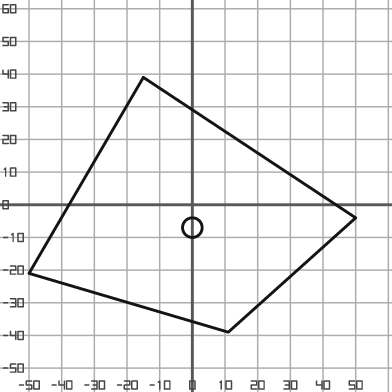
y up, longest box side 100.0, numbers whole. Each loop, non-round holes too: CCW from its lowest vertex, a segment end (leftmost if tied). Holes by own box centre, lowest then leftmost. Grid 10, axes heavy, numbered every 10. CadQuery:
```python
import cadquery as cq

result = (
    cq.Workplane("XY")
    .moveTo(11.0, -39.0)
    .lineTo(50.0, -4.0)
    .lineTo(-15.0, 39.0)
    .lineTo(-50.0, -21.0)
    .close()
    .moveTo(0.0, -7.0)
    .circle(3.0)
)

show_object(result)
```